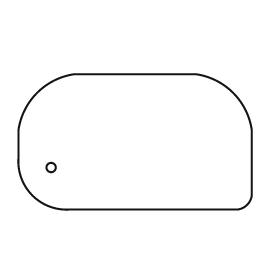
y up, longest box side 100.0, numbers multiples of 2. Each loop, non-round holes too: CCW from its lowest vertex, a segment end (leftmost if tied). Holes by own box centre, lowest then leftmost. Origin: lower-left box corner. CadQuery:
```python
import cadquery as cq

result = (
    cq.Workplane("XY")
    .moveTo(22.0, 0.0)
    .lineTo(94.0, 0.0)
    .threePointArc((98.0, 2.0), (100.0, 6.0))
    .lineTo(100.0, 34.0)
    .threePointArc((92.0, 50.0), (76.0, 58.0))
    .lineTo(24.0, 58.0)
    .threePointArc((8.0, 50.0), (0.0, 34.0))
    .lineTo(0.0, 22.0)
    .threePointArc((6.0, 6.0), (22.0, 0.0))
    .close()
    .moveTo(14.0, 18.0)
    .circle(2.0)
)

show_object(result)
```